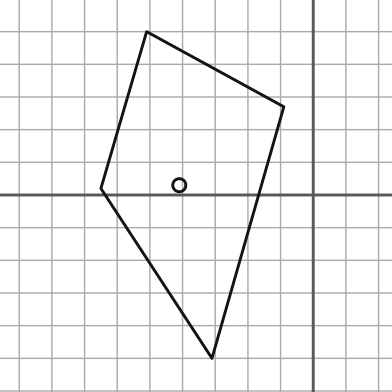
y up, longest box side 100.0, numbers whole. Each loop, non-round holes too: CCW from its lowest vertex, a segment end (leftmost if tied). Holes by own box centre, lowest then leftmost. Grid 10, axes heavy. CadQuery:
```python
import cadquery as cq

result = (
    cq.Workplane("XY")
    .moveTo(-31.0, -50.0)
    .lineTo(-9.0, 27.0)
    .lineTo(-51.0, 50.0)
    .lineTo(-65.0, 2.0)
    .close()
    .moveTo(-41.0, 3.0)
    .circle(2.0)
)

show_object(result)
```